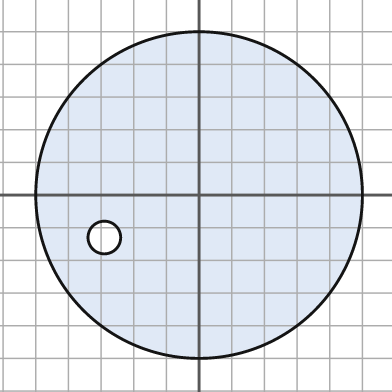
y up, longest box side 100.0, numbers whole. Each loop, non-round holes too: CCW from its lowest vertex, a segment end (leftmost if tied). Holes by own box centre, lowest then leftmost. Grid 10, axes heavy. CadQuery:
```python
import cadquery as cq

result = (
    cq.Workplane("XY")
    .moveTo(0.0, 0.0)
    .circle(50.0)
    .moveTo(-29.0, -13.0)
    .circle(5.0)
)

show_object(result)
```